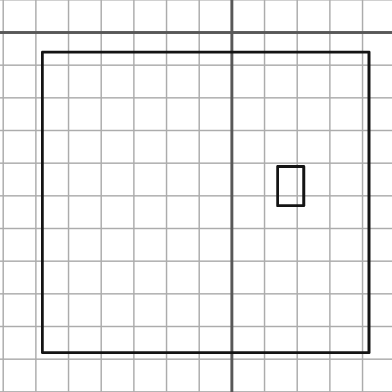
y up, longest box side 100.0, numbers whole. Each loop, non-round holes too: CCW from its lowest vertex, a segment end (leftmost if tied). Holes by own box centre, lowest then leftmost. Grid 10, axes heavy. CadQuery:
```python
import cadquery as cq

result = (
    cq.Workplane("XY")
    .moveTo(-58.0, -98.0)
    .lineTo(42.0, -98.0)
    .lineTo(42.0, -6.0)
    .lineTo(-58.0, -6.0)
    .close()
    .moveTo(14.0, -53.0)
    .lineTo(22.0, -53.0)
    .lineTo(22.0, -41.0)
    .lineTo(14.0, -41.0)
    .close()
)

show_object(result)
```